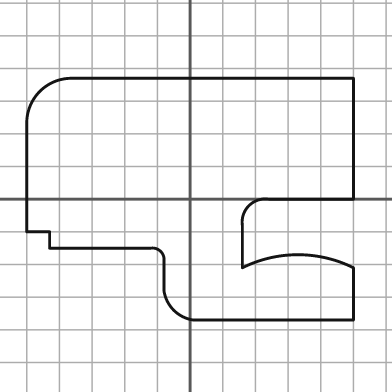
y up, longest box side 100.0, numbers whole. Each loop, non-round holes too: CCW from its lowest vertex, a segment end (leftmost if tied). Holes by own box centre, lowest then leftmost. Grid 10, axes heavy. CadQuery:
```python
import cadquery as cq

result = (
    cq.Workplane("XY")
    .moveTo(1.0, -37.0)
    .lineTo(50.0, -37.0)
    .lineTo(50.0, -21.0)
    .threePointArc((33.0, -17.0), (16.0, -21.0))
    .lineTo(16.0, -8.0)
    .threePointArc((18.0, -2.0), (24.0, 0.0))
    .lineTo(50.0, 0.0)
    .lineTo(50.0, 37.0)
    .lineTo(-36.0, 37.0)
    .threePointArc((-46.0, 33.0), (-50.0, 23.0))
    .lineTo(-50.0, -10.0)
    .lineTo(-43.0, -10.0)
    .lineTo(-43.0, -15.0)
    .lineTo(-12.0, -15.0)
    .threePointArc((-9.0, -16.0), (-8.0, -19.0))
    .lineTo(-8.0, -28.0)
    .threePointArc((-5.0, -34.0), (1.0, -37.0))
    .close()
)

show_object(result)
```